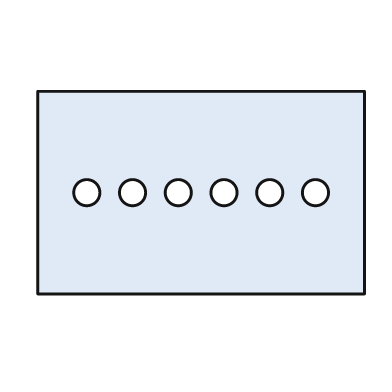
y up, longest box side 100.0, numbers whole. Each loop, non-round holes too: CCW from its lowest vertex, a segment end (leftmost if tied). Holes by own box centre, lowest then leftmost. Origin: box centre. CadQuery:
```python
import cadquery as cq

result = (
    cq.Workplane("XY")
    .moveTo(-50.0, -31.0)
    .lineTo(50.0, -31.0)
    .lineTo(50.0, 31.0)
    .lineTo(-50.0, 31.0)
    .close()
    .moveTo(-35.0, 0.0)
    .circle(4.0)
    .moveTo(-21.0, 0.0)
    .circle(4.0)
    .moveTo(-7.0, 0.0)
    .circle(4.0)
    .moveTo(7.0, 0.0)
    .circle(4.0)
    .moveTo(21.0, 0.0)
    .circle(4.0)
    .moveTo(35.0, 0.0)
    .circle(4.0)
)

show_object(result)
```